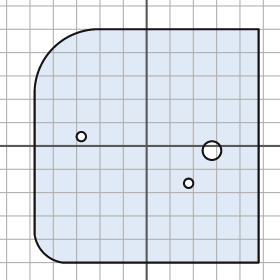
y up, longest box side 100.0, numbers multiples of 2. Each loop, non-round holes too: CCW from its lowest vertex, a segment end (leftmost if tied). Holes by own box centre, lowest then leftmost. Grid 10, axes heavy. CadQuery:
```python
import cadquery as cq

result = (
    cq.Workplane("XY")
    .moveTo(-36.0, -50.0)
    .lineTo(48.0, -50.0)
    .lineTo(48.0, 50.0)
    .lineTo(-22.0, 50.0)
    .threePointArc((-40.0, 42.0), (-48.0, 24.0))
    .lineTo(-48.0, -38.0)
    .threePointArc((-44.0, -46.0), (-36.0, -50.0))
    .close()
    .moveTo(18.0, -16.0)
    .circle(2.0)
    .moveTo(28.0, -2.0)
    .circle(4.0)
    .moveTo(-28.0, 4.0)
    .circle(2.0)
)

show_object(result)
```